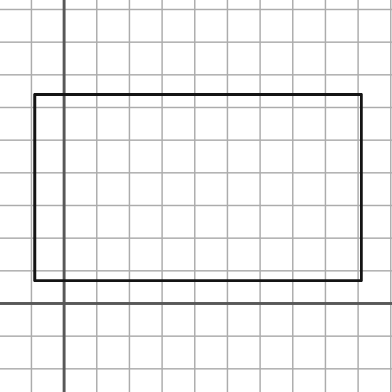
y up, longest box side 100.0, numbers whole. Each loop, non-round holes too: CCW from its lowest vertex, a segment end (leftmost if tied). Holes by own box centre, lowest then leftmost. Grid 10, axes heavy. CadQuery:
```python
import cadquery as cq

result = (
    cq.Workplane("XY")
    .moveTo(-9.0, 7.0)
    .lineTo(91.0, 7.0)
    .lineTo(91.0, 64.0)
    .lineTo(-9.0, 64.0)
    .close()
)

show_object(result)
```